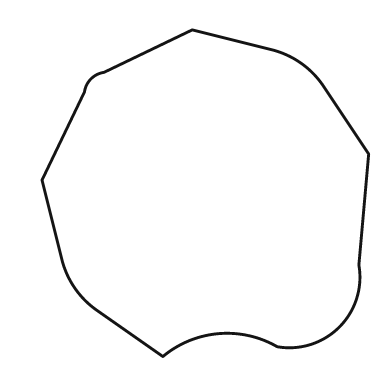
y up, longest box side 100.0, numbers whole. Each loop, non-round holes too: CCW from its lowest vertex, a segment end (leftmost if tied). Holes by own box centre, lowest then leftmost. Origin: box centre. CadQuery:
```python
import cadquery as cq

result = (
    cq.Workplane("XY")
    .moveTo(-13.0, -50.0)
    .threePointArc((4.0, -43.0), (22.0, -47.0))
    .threePointArc((41.0, -41.0), (47.0, -22.0))
    .lineTo(50.0, 12.0)
    .lineTo(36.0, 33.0)
    .threePointArc((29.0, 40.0), (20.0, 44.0))
    .lineTo(-4.0, 50.0)
    .lineTo(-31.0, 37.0)
    .threePointArc((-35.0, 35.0), (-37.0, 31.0))
    .lineTo(-50.0, 4.0)
    .lineTo(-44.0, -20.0)
    .threePointArc((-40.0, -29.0), (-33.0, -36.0))
    .close()
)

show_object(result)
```